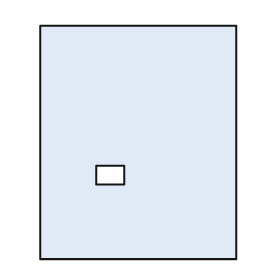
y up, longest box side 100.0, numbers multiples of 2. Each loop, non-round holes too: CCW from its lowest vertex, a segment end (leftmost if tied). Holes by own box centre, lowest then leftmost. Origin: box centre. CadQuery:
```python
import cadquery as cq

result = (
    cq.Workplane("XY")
    .moveTo(-42.0, -50.0)
    .lineTo(42.0, -50.0)
    .lineTo(42.0, 50.0)
    .lineTo(-42.0, 50.0)
    .close()
    .moveTo(-18.0, -18.0)
    .lineTo(-6.0, -18.0)
    .lineTo(-6.0, -10.0)
    .lineTo(-18.0, -10.0)
    .close()
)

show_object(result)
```